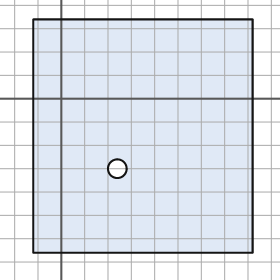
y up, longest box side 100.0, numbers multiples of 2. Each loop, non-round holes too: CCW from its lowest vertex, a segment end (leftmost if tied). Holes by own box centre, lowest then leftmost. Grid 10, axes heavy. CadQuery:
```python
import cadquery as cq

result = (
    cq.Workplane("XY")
    .moveTo(-12.0, -66.0)
    .lineTo(82.0, -66.0)
    .lineTo(82.0, 34.0)
    .lineTo(-12.0, 34.0)
    .close()
    .moveTo(24.0, -30.0)
    .circle(4.0)
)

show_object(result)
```